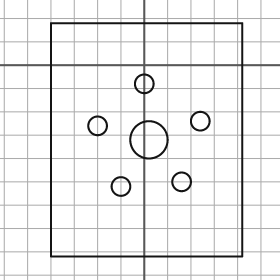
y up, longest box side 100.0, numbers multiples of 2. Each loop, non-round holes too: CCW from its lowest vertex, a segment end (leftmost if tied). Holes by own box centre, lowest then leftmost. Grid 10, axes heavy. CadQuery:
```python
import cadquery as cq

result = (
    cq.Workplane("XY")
    .moveTo(-40.0, -82.0)
    .lineTo(42.0, -82.0)
    .lineTo(42.0, 18.0)
    .lineTo(-40.0, 18.0)
    .close()
    .moveTo(-10.0, -52.0)
    .circle(4.0)
    .moveTo(16.0, -50.0)
    .circle(4.0)
    .moveTo(2.0, -32.0)
    .circle(8.0)
    .moveTo(-20.0, -26.0)
    .circle(4.0)
    .moveTo(24.0, -24.0)
    .circle(4.0)
    .moveTo(0.0, -8.0)
    .circle(4.0)
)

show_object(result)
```